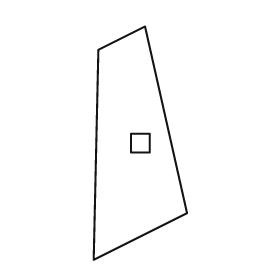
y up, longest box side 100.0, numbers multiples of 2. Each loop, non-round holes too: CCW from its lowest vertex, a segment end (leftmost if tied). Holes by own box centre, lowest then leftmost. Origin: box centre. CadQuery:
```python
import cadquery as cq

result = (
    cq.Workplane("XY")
    .moveTo(-20.0, -50.0)
    .lineTo(20.0, -30.0)
    .lineTo(2.0, 50.0)
    .lineTo(-18.0, 40.0)
    .close()
    .moveTo(-4.0, -4.0)
    .lineTo(4.0, -4.0)
    .lineTo(4.0, 4.0)
    .lineTo(-4.0, 4.0)
    .close()
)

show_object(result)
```